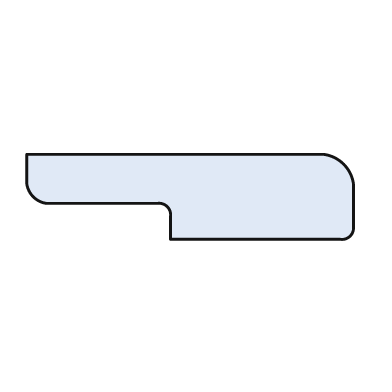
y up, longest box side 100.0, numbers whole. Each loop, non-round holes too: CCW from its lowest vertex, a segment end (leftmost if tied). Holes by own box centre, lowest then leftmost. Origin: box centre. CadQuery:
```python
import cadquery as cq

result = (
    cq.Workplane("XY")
    .moveTo(-6.0, -13.0)
    .lineTo(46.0, -13.0)
    .threePointArc((49.0, -12.0), (50.0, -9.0))
    .lineTo(50.0, 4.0)
    .threePointArc((47.0, 10.0), (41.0, 13.0))
    .lineTo(-50.0, 13.0)
    .lineTo(-50.0, 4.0)
    .threePointArc((-48.0, 0.0), (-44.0, -2.0))
    .lineTo(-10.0, -2.0)
    .threePointArc((-7.0, -3.0), (-6.0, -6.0))
    .close()
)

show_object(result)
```